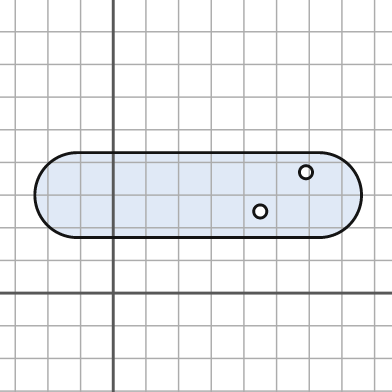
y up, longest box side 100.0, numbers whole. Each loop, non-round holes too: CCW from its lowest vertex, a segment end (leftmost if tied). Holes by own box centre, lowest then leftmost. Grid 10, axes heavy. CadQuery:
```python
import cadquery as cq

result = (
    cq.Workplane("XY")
    .moveTo(-11.0, 17.0)
    .lineTo(63.0, 17.0)
    .threePointArc((76.0, 30.0), (63.0, 43.0))
    .lineTo(-11.0, 43.0)
    .threePointArc((-24.0, 30.0), (-11.0, 17.0))
    .close()
    .moveTo(45.0, 25.0)
    .circle(2.0)
    .moveTo(59.0, 37.0)
    .circle(2.0)
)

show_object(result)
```